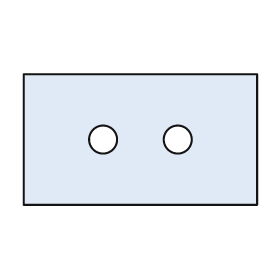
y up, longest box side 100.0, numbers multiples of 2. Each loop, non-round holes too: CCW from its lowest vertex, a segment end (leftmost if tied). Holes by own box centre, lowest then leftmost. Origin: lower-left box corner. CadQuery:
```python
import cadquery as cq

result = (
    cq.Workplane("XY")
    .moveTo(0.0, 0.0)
    .lineTo(100.0, 0.0)
    .lineTo(100.0, 56.0)
    .lineTo(0.0, 56.0)
    .close()
    .moveTo(34.0, 28.0)
    .circle(6.0)
    .moveTo(66.0, 28.0)
    .circle(6.0)
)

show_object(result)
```